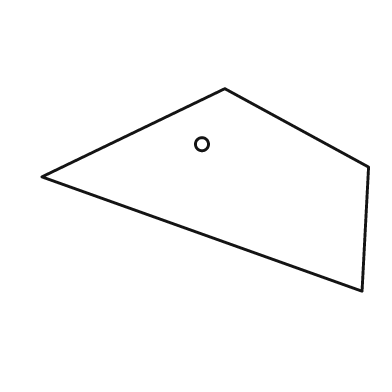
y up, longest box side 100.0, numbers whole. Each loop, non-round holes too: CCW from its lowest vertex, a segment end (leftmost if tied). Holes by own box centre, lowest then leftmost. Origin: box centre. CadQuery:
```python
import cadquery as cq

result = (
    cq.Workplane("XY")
    .moveTo(48.0, -31.0)
    .lineTo(50.0, 7.0)
    .lineTo(6.0, 31.0)
    .lineTo(-50.0, 4.0)
    .close()
    .moveTo(-1.0, 14.0)
    .circle(2.0)
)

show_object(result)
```